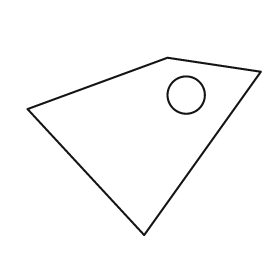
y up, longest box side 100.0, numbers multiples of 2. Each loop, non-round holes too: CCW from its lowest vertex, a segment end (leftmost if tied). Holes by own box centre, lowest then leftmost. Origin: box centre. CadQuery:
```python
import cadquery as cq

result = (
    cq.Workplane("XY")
    .moveTo(0.0, -38.0)
    .lineTo(50.0, 32.0)
    .lineTo(10.0, 38.0)
    .lineTo(-50.0, 16.0)
    .close()
    .moveTo(18.0, 22.0)
    .circle(8.0)
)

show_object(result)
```